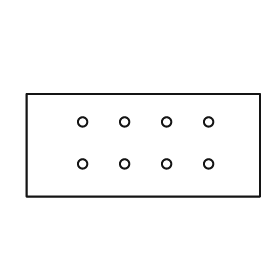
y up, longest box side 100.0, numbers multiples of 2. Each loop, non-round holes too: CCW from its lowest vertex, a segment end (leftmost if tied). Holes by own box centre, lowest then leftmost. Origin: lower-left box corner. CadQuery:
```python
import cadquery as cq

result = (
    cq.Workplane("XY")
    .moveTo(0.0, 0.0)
    .lineTo(100.0, 0.0)
    .lineTo(100.0, 44.0)
    .lineTo(0.0, 44.0)
    .close()
    .moveTo(24.0, 14.0)
    .circle(2.0)
    .moveTo(42.0, 14.0)
    .circle(2.0)
    .moveTo(60.0, 14.0)
    .circle(2.0)
    .moveTo(78.0, 14.0)
    .circle(2.0)
    .moveTo(24.0, 32.0)
    .circle(2.0)
    .moveTo(42.0, 32.0)
    .circle(2.0)
    .moveTo(60.0, 32.0)
    .circle(2.0)
    .moveTo(78.0, 32.0)
    .circle(2.0)
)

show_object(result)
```